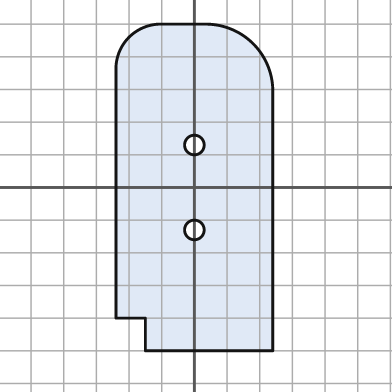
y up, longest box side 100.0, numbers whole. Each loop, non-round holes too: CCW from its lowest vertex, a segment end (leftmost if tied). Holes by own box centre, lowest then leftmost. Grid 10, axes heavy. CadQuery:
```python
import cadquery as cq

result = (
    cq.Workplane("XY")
    .moveTo(-15.0, -50.0)
    .lineTo(24.0, -50.0)
    .lineTo(24.0, 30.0)
    .threePointArc((18.0, 44.0), (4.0, 50.0))
    .lineTo(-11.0, 50.0)
    .threePointArc((-20.0, 46.0), (-24.0, 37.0))
    .lineTo(-24.0, -40.0)
    .lineTo(-15.0, -40.0)
    .close()
    .moveTo(0.0, -13.0)
    .circle(3.0)
    .moveTo(0.0, 13.0)
    .circle(3.0)
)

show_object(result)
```